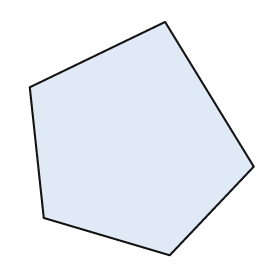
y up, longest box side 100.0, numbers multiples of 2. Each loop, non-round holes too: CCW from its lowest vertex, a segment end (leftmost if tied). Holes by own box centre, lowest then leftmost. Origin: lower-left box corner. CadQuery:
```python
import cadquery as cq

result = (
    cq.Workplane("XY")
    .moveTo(60.0, 0.0)
    .lineTo(96.0, 38.0)
    .lineTo(58.0, 100.0)
    .lineTo(0.0, 72.0)
    .lineTo(6.0, 16.0)
    .close()
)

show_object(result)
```